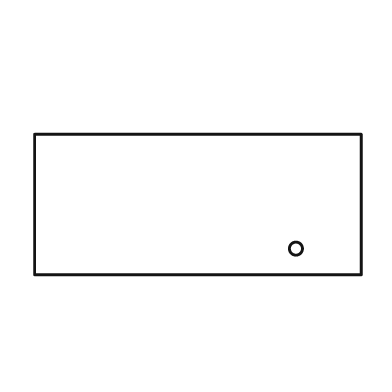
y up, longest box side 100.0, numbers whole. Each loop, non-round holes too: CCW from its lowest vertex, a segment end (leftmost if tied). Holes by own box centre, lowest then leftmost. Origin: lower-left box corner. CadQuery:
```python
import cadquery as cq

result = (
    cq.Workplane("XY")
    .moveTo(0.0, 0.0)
    .lineTo(100.0, 0.0)
    .lineTo(100.0, 43.0)
    .lineTo(0.0, 43.0)
    .close()
    .moveTo(80.0, 8.0)
    .circle(2.0)
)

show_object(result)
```